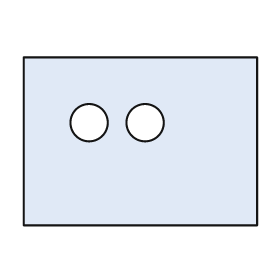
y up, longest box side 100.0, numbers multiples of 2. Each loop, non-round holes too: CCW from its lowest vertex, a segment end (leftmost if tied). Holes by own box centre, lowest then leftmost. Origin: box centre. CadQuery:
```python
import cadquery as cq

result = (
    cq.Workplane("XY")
    .moveTo(-50.0, -36.0)
    .lineTo(50.0, -36.0)
    .lineTo(50.0, 36.0)
    .lineTo(-50.0, 36.0)
    .close()
    .moveTo(-22.0, 8.0)
    .circle(8.0)
    .moveTo(2.0, 8.0)
    .circle(8.0)
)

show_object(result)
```